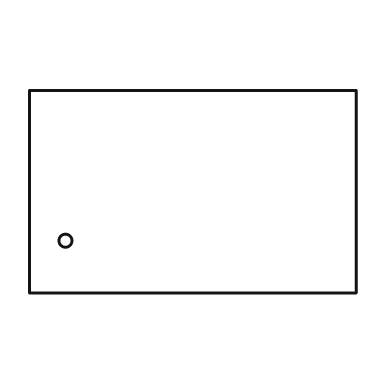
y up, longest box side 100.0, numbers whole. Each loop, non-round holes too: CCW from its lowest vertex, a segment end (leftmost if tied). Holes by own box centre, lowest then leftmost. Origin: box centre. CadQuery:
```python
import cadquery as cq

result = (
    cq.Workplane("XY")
    .moveTo(-50.0, -31.0)
    .lineTo(50.0, -31.0)
    .lineTo(50.0, 31.0)
    .lineTo(-50.0, 31.0)
    .close()
    .moveTo(-39.0, -15.0)
    .circle(2.0)
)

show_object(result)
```